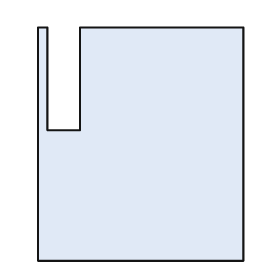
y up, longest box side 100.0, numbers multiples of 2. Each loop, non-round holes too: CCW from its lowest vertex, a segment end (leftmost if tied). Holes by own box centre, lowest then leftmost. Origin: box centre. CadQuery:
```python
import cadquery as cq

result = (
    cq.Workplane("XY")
    .moveTo(-44.0, -50.0)
    .lineTo(44.0, -50.0)
    .lineTo(44.0, 50.0)
    .lineTo(-26.0, 50.0)
    .lineTo(-26.0, 6.0)
    .lineTo(-40.0, 6.0)
    .lineTo(-40.0, 50.0)
    .lineTo(-44.0, 50.0)
    .close()
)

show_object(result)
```